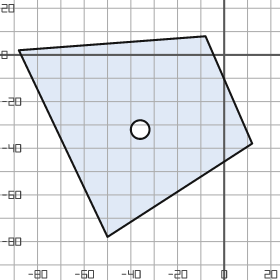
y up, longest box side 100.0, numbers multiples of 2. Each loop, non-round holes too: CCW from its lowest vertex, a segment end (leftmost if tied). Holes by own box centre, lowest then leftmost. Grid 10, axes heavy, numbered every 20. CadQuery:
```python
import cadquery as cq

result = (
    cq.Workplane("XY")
    .moveTo(-50.0, -78.0)
    .lineTo(12.0, -38.0)
    .lineTo(-8.0, 8.0)
    .lineTo(-88.0, 2.0)
    .close()
    .moveTo(-36.0, -32.0)
    .circle(4.0)
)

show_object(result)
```